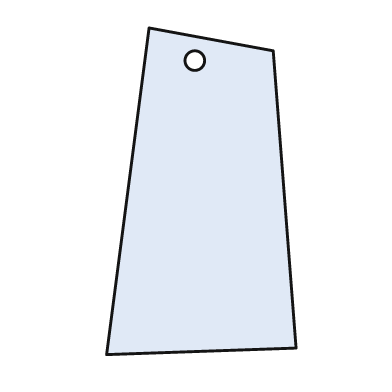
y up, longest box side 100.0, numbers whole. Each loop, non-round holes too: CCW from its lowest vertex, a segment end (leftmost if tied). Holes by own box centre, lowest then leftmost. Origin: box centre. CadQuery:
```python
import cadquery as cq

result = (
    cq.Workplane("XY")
    .moveTo(-29.0, -50.0)
    .lineTo(29.0, -48.0)
    .lineTo(22.0, 43.0)
    .lineTo(-16.0, 50.0)
    .close()
    .moveTo(-2.0, 40.0)
    .circle(3.0)
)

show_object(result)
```